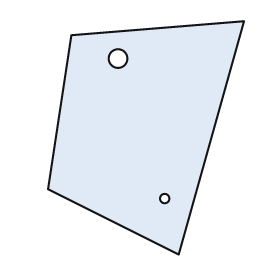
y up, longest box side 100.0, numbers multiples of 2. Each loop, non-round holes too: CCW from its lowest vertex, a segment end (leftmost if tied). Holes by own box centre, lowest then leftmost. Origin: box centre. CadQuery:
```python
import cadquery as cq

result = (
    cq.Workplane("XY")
    .moveTo(14.0, -50.0)
    .lineTo(42.0, 50.0)
    .lineTo(-32.0, 44.0)
    .lineTo(-42.0, -22.0)
    .close()
    .moveTo(8.0, -26.0)
    .circle(2.0)
    .moveTo(-12.0, 34.0)
    .circle(4.0)
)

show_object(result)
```